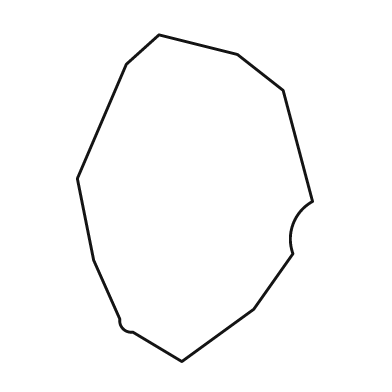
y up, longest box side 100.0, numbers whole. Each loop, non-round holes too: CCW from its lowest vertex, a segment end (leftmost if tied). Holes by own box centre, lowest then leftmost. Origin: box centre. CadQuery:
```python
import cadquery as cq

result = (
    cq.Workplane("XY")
    .moveTo(-4.0, -50.0)
    .lineTo(18.0, -34.0)
    .lineTo(30.0, -17.0)
    .threePointArc((30.0, -8.0), (36.0, -1.0))
    .lineTo(27.0, 33.0)
    .lineTo(13.0, 44.0)
    .lineTo(-11.0, 50.0)
    .lineTo(-21.0, 41.0)
    .lineTo(-36.0, 6.0)
    .lineTo(-31.0, -19.0)
    .lineTo(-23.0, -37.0)
    .threePointArc((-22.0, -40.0), (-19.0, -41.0))
    .close()
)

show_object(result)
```